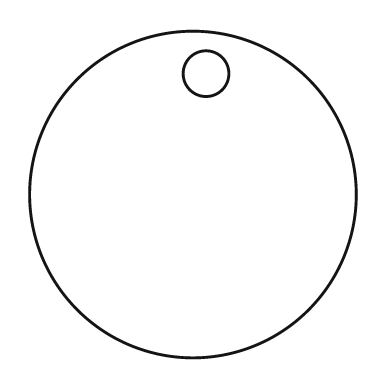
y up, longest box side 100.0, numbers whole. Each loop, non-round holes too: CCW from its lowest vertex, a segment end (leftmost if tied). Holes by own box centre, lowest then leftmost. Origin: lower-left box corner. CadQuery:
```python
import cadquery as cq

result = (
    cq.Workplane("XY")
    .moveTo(50.0, 50.0)
    .circle(50.0)
    .moveTo(54.0, 87.0)
    .circle(7.0)
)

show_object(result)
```